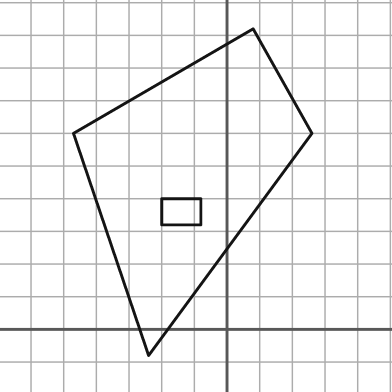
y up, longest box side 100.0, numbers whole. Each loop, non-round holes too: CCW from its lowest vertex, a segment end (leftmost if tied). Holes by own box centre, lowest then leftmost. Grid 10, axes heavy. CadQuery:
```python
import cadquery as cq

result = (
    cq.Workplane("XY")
    .moveTo(-24.0, -8.0)
    .lineTo(26.0, 60.0)
    .lineTo(8.0, 92.0)
    .lineTo(-47.0, 60.0)
    .close()
    .moveTo(-20.0, 32.0)
    .lineTo(-8.0, 32.0)
    .lineTo(-8.0, 40.0)
    .lineTo(-20.0, 40.0)
    .close()
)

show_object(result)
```